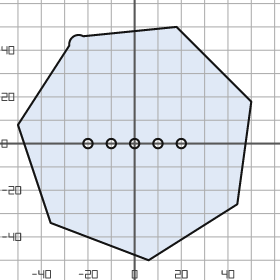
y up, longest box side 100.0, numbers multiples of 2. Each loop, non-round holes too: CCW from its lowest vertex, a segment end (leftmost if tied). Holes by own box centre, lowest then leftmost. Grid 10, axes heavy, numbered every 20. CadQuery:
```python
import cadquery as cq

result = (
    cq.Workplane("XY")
    .moveTo(6.0, -50.0)
    .lineTo(44.0, -26.0)
    .lineTo(50.0, 18.0)
    .lineTo(18.0, 50.0)
    .lineTo(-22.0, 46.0)
    .threePointArc((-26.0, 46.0), (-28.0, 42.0))
    .lineTo(-50.0, 8.0)
    .lineTo(-36.0, -34.0)
    .close()
    .moveTo(-20.0, 0.0)
    .circle(2.0)
    .moveTo(-10.0, 0.0)
    .circle(2.0)
    .moveTo(0.0, 0.0)
    .circle(2.0)
    .moveTo(10.0, 0.0)
    .circle(2.0)
    .moveTo(20.0, 0.0)
    .circle(2.0)
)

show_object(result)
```